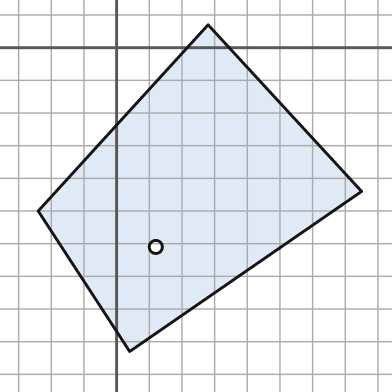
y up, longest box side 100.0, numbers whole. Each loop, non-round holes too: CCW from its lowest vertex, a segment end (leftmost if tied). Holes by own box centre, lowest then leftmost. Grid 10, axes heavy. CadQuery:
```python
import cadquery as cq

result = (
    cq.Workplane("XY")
    .moveTo(4.0, -93.0)
    .lineTo(75.0, -44.0)
    .lineTo(28.0, 7.0)
    .lineTo(-24.0, -50.0)
    .close()
    .moveTo(12.0, -61.0)
    .circle(2.0)
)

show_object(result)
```